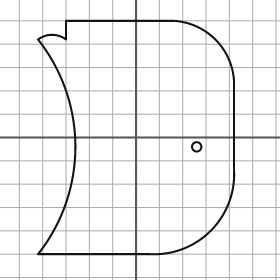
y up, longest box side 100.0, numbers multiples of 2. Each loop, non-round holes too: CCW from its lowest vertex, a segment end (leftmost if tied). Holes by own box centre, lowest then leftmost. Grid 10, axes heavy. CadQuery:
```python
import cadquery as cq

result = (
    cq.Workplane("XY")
    .moveTo(-42.0, -50.0)
    .lineTo(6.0, -50.0)
    .threePointArc((32.0, -40.0), (42.0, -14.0))
    .lineTo(42.0, 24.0)
    .threePointArc((34.0, 42.0), (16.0, 50.0))
    .lineTo(-30.0, 50.0)
    .lineTo(-30.0, 42.0)
    .threePointArc((-36.0, 44.0), (-42.0, 42.0))
    .threePointArc((-26.0, -4.0), (-42.0, -50.0))
    .close()
    .moveTo(26.0, -4.0)
    .circle(2.0)
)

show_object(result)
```